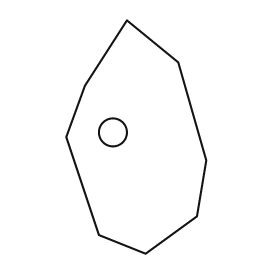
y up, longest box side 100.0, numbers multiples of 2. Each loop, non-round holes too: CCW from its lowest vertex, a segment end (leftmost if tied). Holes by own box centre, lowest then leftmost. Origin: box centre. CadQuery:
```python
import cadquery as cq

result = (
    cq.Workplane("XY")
    .moveTo(4.0, -50.0)
    .lineTo(26.0, -34.0)
    .lineTo(30.0, -10.0)
    .lineTo(18.0, 32.0)
    .lineTo(-4.0, 50.0)
    .lineTo(-22.0, 22.0)
    .lineTo(-30.0, 0.0)
    .lineTo(-16.0, -42.0)
    .close()
    .moveTo(-10.0, 2.0)
    .circle(6.0)
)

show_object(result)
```